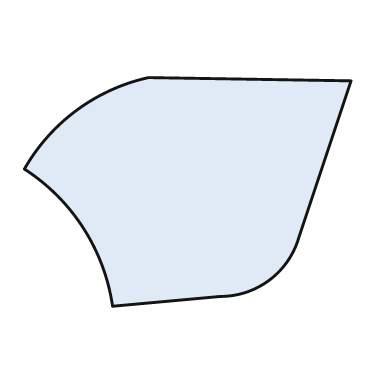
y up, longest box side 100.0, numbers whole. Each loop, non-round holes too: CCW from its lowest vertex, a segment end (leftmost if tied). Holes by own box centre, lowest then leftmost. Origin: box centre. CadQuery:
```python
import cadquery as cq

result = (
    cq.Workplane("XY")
    .moveTo(-23.0, -35.0)
    .lineTo(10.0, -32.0)
    .threePointArc((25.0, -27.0), (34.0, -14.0))
    .lineTo(50.0, 34.0)
    .lineTo(-12.0, 35.0)
    .threePointArc((-34.0, 25.0), (-50.0, 7.0))
    .threePointArc((-32.0, -11.0), (-23.0, -35.0))
    .close()
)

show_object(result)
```